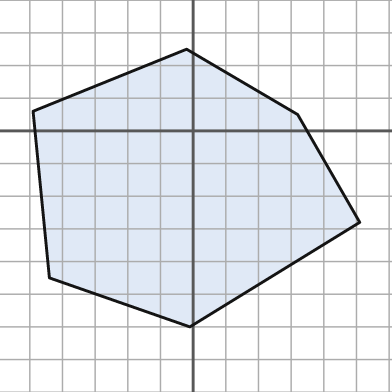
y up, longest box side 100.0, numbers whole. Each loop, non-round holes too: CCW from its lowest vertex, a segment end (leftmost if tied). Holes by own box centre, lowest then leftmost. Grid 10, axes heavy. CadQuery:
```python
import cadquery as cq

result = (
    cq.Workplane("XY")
    .moveTo(-1.0, -60.0)
    .lineTo(51.0, -28.0)
    .lineTo(32.0, 5.0)
    .lineTo(-2.0, 25.0)
    .lineTo(-49.0, 6.0)
    .lineTo(-44.0, -45.0)
    .close()
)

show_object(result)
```